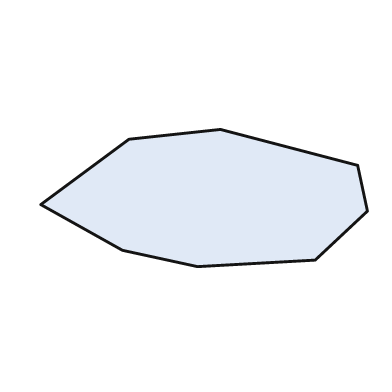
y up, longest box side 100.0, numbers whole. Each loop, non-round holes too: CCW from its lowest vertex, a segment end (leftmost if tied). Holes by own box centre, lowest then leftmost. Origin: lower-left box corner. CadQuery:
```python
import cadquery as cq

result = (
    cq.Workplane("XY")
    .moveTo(48.0, 0.0)
    .lineTo(84.0, 2.0)
    .lineTo(100.0, 17.0)
    .lineTo(97.0, 31.0)
    .lineTo(55.0, 42.0)
    .lineTo(27.0, 39.0)
    .lineTo(0.0, 19.0)
    .lineTo(25.0, 5.0)
    .close()
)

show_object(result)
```